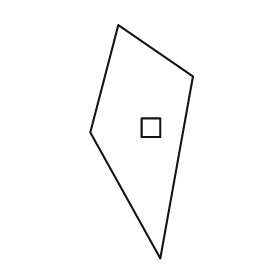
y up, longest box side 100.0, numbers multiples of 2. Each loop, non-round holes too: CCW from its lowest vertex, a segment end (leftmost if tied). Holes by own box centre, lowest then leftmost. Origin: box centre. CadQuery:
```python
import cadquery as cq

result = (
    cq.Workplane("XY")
    .moveTo(8.0, -50.0)
    .lineTo(22.0, 28.0)
    .lineTo(-10.0, 50.0)
    .lineTo(-22.0, 4.0)
    .close()
    .moveTo(0.0, 2.0)
    .lineTo(8.0, 2.0)
    .lineTo(8.0, 10.0)
    .lineTo(0.0, 10.0)
    .close()
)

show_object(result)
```